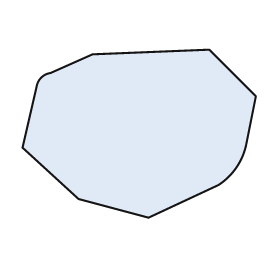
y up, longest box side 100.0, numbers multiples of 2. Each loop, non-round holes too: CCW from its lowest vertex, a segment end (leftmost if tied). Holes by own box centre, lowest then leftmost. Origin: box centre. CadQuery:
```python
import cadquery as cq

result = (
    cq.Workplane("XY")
    .moveTo(4.0, -36.0)
    .lineTo(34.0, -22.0)
    .threePointArc((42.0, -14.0), (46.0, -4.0))
    .lineTo(50.0, 16.0)
    .lineTo(30.0, 36.0)
    .lineTo(-20.0, 34.0)
    .lineTo(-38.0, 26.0)
    .threePointArc((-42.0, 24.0), (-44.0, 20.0))
    .lineTo(-50.0, -6.0)
    .lineTo(-26.0, -28.0)
    .close()
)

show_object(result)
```